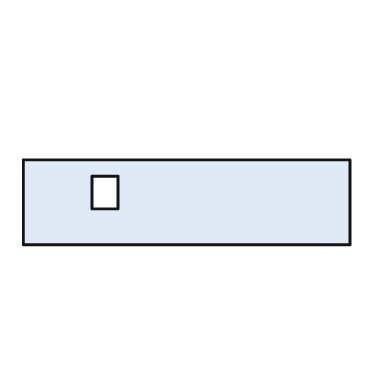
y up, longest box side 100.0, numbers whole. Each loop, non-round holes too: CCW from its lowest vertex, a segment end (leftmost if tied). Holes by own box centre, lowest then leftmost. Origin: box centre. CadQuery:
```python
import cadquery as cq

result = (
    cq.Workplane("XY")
    .moveTo(-50.0, -13.0)
    .lineTo(50.0, -13.0)
    .lineTo(50.0, 13.0)
    .lineTo(-50.0, 13.0)
    .close()
    .moveTo(-29.0, -2.0)
    .lineTo(-21.0, -2.0)
    .lineTo(-21.0, 8.0)
    .lineTo(-29.0, 8.0)
    .close()
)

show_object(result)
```